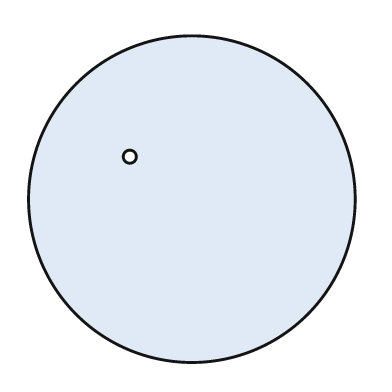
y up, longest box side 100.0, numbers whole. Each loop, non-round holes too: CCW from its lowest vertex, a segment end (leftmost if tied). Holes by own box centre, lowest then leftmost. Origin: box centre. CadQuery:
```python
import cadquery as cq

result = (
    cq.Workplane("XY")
    .moveTo(0.0, 0.0)
    .circle(50.0)
    .moveTo(-19.0, 13.0)
    .circle(2.0)
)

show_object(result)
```